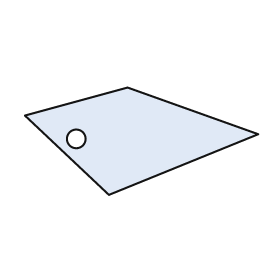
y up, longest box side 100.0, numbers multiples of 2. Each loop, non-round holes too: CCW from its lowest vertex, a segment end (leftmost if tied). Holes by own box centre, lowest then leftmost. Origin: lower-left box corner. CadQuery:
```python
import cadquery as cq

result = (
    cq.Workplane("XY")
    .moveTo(36.0, 0.0)
    .lineTo(100.0, 26.0)
    .lineTo(44.0, 46.0)
    .lineTo(0.0, 34.0)
    .close()
    .moveTo(22.0, 24.0)
    .circle(4.0)
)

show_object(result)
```